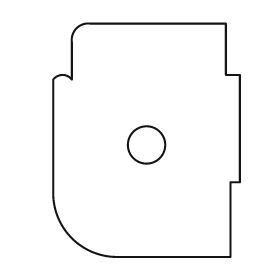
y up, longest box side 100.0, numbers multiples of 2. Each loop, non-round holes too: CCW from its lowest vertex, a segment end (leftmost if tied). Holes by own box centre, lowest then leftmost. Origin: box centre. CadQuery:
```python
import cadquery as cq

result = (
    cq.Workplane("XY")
    .moveTo(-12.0, -50.0)
    .lineTo(36.0, -50.0)
    .lineTo(36.0, -18.0)
    .lineTo(40.0, -18.0)
    .lineTo(40.0, 28.0)
    .lineTo(34.0, 28.0)
    .lineTo(34.0, 50.0)
    .lineTo(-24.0, 50.0)
    .threePointArc((-30.0, 48.0), (-32.0, 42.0))
    .lineTo(-32.0, 26.0)
    .threePointArc((-36.0, 28.0), (-40.0, 26.0))
    .lineTo(-40.0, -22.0)
    .threePointArc((-32.0, -42.0), (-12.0, -50.0))
    .close()
    .moveTo(0.0, -2.0)
    .circle(8.0)
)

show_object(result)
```